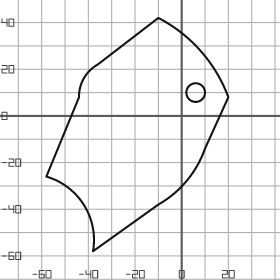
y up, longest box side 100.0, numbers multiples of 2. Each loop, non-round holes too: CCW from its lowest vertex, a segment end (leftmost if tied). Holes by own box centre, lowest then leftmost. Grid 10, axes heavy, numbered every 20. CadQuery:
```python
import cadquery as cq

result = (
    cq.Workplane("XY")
    .moveTo(-38.0, -58.0)
    .lineTo(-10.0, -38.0)
    .threePointArc((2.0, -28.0), (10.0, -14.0))
    .lineTo(20.0, 8.0)
    .threePointArc((8.0, 28.0), (-10.0, 42.0))
    .lineTo(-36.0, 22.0)
    .threePointArc((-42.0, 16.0), (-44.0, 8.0))
    .lineTo(-58.0, -26.0)
    .threePointArc((-42.0, -38.0), (-38.0, -58.0))
    .close()
    .moveTo(6.0, 10.0)
    .circle(4.0)
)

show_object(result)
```